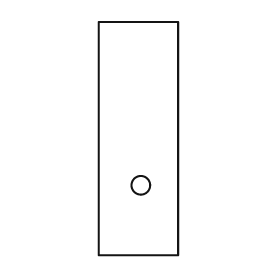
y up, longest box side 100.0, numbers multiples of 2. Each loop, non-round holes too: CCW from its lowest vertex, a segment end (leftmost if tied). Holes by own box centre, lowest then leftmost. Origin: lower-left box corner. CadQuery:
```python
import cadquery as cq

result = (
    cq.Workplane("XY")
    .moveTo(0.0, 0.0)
    .lineTo(34.0, 0.0)
    .lineTo(34.0, 100.0)
    .lineTo(0.0, 100.0)
    .close()
    .moveTo(18.0, 30.0)
    .circle(4.0)
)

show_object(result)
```